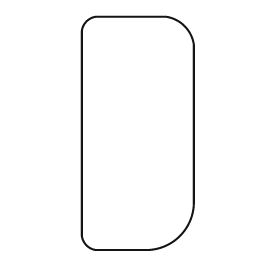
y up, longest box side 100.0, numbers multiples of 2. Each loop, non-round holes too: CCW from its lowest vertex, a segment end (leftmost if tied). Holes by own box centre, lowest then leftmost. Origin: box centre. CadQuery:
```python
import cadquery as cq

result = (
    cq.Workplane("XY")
    .moveTo(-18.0, -50.0)
    .lineTo(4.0, -50.0)
    .threePointArc((18.0, -44.0), (24.0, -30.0))
    .lineTo(24.0, 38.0)
    .threePointArc((20.0, 46.0), (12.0, 50.0))
    .lineTo(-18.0, 50.0)
    .threePointArc((-22.0, 48.0), (-24.0, 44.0))
    .lineTo(-24.0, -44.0)
    .threePointArc((-22.0, -48.0), (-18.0, -50.0))
    .close()
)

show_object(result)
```